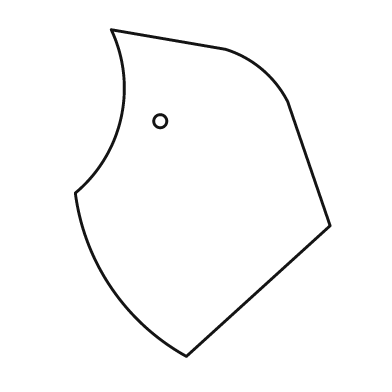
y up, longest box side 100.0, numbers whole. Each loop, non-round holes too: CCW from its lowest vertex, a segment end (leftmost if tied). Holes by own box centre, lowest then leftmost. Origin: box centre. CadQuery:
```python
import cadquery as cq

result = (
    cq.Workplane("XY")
    .moveTo(-5.0, -50.0)
    .lineTo(39.0, -10.0)
    .lineTo(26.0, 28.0)
    .threePointArc((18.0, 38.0), (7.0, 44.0))
    .lineTo(-28.0, 50.0)
    .threePointArc((-25.0, 23.0), (-39.0, 0.0))
    .threePointArc((-28.0, -29.0), (-5.0, -50.0))
    .close()
    .moveTo(-13.0, 22.0)
    .circle(2.0)
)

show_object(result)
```